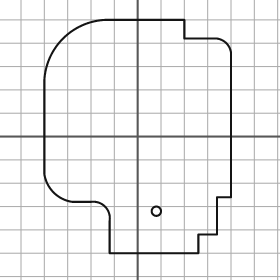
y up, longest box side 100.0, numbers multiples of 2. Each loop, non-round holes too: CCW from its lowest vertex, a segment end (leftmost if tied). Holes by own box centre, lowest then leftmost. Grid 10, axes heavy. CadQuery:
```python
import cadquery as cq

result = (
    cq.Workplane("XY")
    .moveTo(-12.0, -50.0)
    .lineTo(26.0, -50.0)
    .lineTo(26.0, -42.0)
    .lineTo(34.0, -42.0)
    .lineTo(34.0, -26.0)
    .lineTo(40.0, -26.0)
    .lineTo(40.0, 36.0)
    .threePointArc((38.0, 40.0), (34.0, 42.0))
    .lineTo(20.0, 42.0)
    .lineTo(20.0, 50.0)
    .lineTo(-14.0, 50.0)
    .threePointArc((-32.0, 42.0), (-40.0, 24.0))
    .lineTo(-40.0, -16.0)
    .threePointArc((-36.0, -24.0), (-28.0, -28.0))
    .lineTo(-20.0, -28.0)
    .threePointArc((-14.0, -30.0), (-12.0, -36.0))
    .close()
    .moveTo(8.0, -32.0)
    .circle(2.0)
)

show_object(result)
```